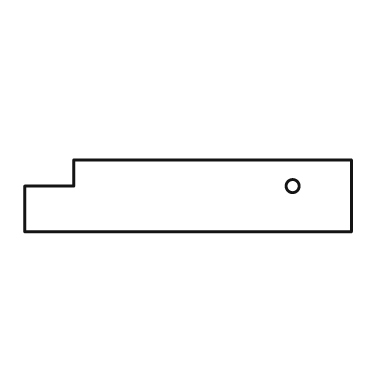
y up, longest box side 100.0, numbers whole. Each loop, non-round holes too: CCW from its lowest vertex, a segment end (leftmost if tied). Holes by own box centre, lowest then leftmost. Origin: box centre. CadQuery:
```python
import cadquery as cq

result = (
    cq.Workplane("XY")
    .moveTo(-50.0, -11.0)
    .lineTo(50.0, -11.0)
    .lineTo(50.0, 11.0)
    .lineTo(-35.0, 11.0)
    .lineTo(-35.0, 3.0)
    .lineTo(-50.0, 3.0)
    .close()
    .moveTo(32.0, 3.0)
    .circle(2.0)
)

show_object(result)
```